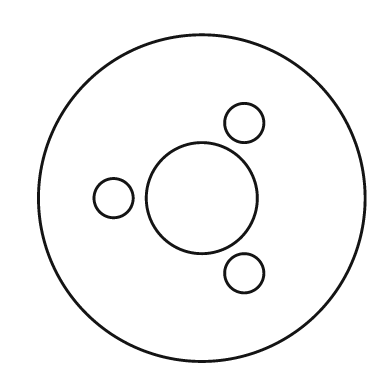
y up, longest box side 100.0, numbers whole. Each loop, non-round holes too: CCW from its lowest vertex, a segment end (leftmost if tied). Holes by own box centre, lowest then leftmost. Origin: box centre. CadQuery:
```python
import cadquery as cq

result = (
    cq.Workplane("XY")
    .moveTo(0.0, 0.0)
    .circle(50.0)
    .moveTo(13.0, -23.0)
    .circle(6.0)
    .moveTo(-27.0, 0.0)
    .circle(6.0)
    .moveTo(0.0, 0.0)
    .circle(17.0)
    .moveTo(13.0, 23.0)
    .circle(6.0)
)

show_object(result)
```